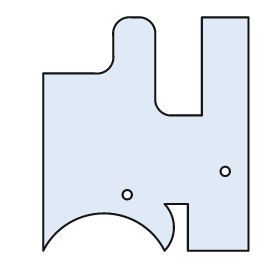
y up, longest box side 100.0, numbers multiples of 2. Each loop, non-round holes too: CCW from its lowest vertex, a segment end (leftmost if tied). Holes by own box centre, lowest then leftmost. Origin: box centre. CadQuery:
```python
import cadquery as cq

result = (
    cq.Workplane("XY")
    .moveTo(-44.0, -50.0)
    .threePointArc((-18.0, -34.0), (8.0, -50.0))
    .threePointArc((12.0, -40.0), (8.0, -30.0))
    .lineTo(18.0, -30.0)
    .lineTo(18.0, -50.0)
    .lineTo(44.0, -50.0)
    .lineTo(44.0, 50.0)
    .lineTo(24.0, 50.0)
    .lineTo(24.0, 8.0)
    .lineTo(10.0, 8.0)
    .threePointArc((6.0, 10.0), (4.0, 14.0))
    .lineTo(4.0, 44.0)
    .threePointArc((2.0, 48.0), (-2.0, 50.0))
    .lineTo(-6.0, 50.0)
    .threePointArc((-12.0, 48.0), (-14.0, 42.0))
    .lineTo(-14.0, 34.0)
    .threePointArc((-16.0, 28.0), (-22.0, 26.0))
    .lineTo(-44.0, 26.0)
    .close()
    .moveTo(-8.0, -26.0)
    .circle(2.0)
    .moveTo(34.0, -16.0)
    .circle(2.0)
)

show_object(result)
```